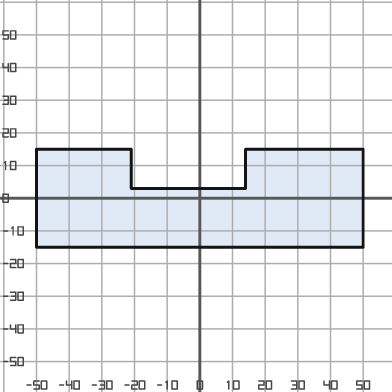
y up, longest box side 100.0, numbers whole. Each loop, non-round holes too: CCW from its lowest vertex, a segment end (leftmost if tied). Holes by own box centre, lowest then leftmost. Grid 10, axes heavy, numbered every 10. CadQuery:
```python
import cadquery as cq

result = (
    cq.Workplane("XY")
    .moveTo(-50.0, -15.0)
    .lineTo(50.0, -15.0)
    .lineTo(50.0, 15.0)
    .lineTo(14.0, 15.0)
    .lineTo(14.0, 3.0)
    .lineTo(-21.0, 3.0)
    .lineTo(-21.0, 15.0)
    .lineTo(-50.0, 15.0)
    .close()
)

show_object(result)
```